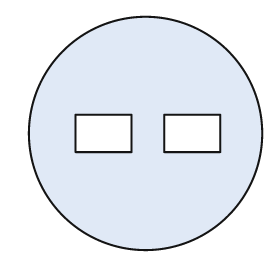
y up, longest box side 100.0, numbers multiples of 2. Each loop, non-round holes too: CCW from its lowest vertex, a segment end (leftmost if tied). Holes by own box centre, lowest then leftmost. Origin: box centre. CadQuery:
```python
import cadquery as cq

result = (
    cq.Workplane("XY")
    .moveTo(0.0, 0.0)
    .circle(50.0)
    .moveTo(-30.0, -8.0)
    .lineTo(-6.0, -8.0)
    .lineTo(-6.0, 8.0)
    .lineTo(-30.0, 8.0)
    .close()
    .moveTo(8.0, -8.0)
    .lineTo(32.0, -8.0)
    .lineTo(32.0, 8.0)
    .lineTo(8.0, 8.0)
    .close()
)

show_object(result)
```